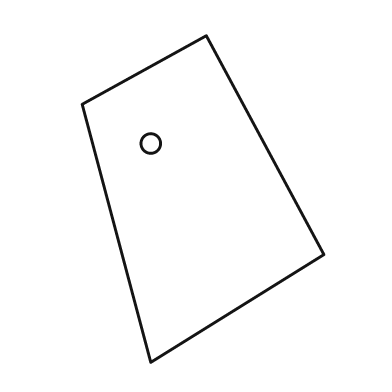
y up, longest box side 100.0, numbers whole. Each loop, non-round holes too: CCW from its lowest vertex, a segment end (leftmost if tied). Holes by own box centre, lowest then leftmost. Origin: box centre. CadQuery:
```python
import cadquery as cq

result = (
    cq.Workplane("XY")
    .moveTo(-16.0, -50.0)
    .lineTo(37.0, -17.0)
    .lineTo(1.0, 50.0)
    .lineTo(-37.0, 29.0)
    .close()
    .moveTo(-16.0, 17.0)
    .circle(3.0)
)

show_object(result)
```